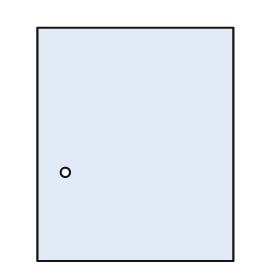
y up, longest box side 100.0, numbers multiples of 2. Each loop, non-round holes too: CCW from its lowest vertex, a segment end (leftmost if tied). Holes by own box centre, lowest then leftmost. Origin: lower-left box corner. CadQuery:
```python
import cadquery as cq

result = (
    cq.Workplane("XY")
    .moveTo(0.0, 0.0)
    .lineTo(84.0, 0.0)
    .lineTo(84.0, 100.0)
    .lineTo(0.0, 100.0)
    .close()
    .moveTo(12.0, 38.0)
    .circle(2.0)
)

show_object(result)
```